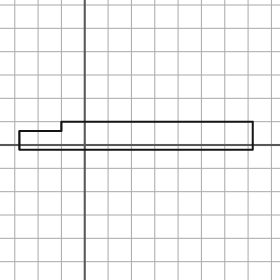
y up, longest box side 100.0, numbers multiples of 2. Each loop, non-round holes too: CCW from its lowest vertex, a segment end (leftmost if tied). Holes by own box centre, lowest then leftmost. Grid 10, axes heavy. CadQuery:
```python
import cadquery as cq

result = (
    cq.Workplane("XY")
    .moveTo(-28.0, -2.0)
    .lineTo(72.0, -2.0)
    .lineTo(72.0, 10.0)
    .lineTo(-10.0, 10.0)
    .lineTo(-10.0, 6.0)
    .lineTo(-28.0, 6.0)
    .close()
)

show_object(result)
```